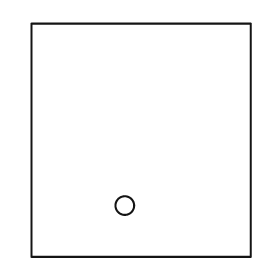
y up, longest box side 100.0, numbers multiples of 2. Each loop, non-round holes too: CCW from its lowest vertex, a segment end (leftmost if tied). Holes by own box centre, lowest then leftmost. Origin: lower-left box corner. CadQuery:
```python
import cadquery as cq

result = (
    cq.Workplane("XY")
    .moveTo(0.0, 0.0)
    .lineTo(94.0, 0.0)
    .lineTo(94.0, 100.0)
    .lineTo(0.0, 100.0)
    .close()
    .moveTo(40.0, 22.0)
    .circle(4.0)
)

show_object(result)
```